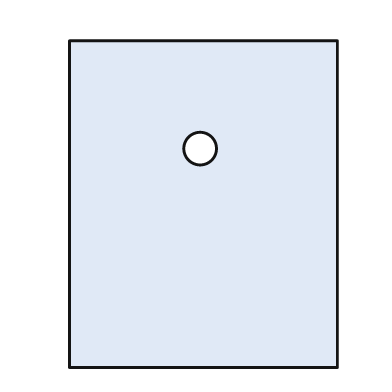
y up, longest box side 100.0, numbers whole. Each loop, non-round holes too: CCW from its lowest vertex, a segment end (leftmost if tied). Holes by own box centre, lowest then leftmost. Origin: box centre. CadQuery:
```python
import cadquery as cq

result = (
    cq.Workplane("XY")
    .moveTo(-41.0, -50.0)
    .lineTo(41.0, -50.0)
    .lineTo(41.0, 50.0)
    .lineTo(-41.0, 50.0)
    .close()
    .moveTo(-1.0, 17.0)
    .circle(5.0)
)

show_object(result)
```